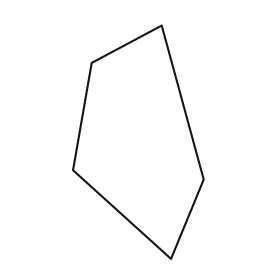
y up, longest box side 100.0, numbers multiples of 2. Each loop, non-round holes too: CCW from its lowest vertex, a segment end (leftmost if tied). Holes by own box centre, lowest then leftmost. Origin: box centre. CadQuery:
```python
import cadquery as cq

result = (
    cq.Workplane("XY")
    .moveTo(14.0, -50.0)
    .lineTo(28.0, -16.0)
    .lineTo(10.0, 50.0)
    .lineTo(-20.0, 34.0)
    .lineTo(-28.0, -12.0)
    .close()
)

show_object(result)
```